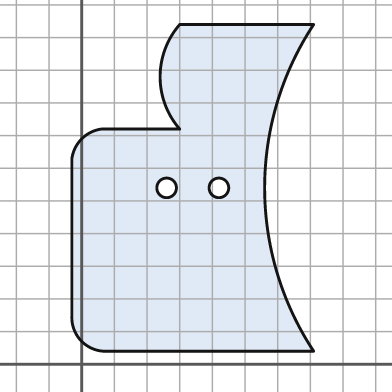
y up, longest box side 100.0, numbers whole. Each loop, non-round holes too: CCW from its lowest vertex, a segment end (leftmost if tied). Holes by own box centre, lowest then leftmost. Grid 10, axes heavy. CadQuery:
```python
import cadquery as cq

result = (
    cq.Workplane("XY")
    .moveTo(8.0, 4.0)
    .lineTo(71.0, 4.0)
    .threePointArc((56.0, 54.0), (71.0, 104.0))
    .lineTo(30.0, 104.0)
    .threePointArc((24.0, 88.0), (30.0, 72.0))
    .lineTo(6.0, 72.0)
    .threePointArc((0.0, 69.0), (-3.0, 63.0))
    .lineTo(-3.0, 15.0)
    .threePointArc((0.0, 7.0), (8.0, 4.0))
    .close()
    .moveTo(26.0, 54.0)
    .circle(3.0)
    .moveTo(42.0, 54.0)
    .circle(3.0)
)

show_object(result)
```